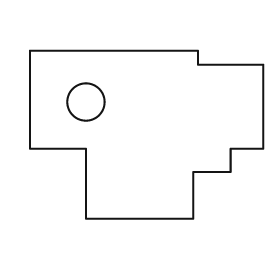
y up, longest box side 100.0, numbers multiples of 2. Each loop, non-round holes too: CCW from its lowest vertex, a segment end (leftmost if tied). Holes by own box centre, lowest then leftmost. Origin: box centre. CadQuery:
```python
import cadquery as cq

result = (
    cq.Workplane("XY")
    .moveTo(-26.0, -36.0)
    .lineTo(20.0, -36.0)
    .lineTo(20.0, -16.0)
    .lineTo(36.0, -16.0)
    .lineTo(36.0, -6.0)
    .lineTo(50.0, -6.0)
    .lineTo(50.0, 30.0)
    .lineTo(22.0, 30.0)
    .lineTo(22.0, 36.0)
    .lineTo(-50.0, 36.0)
    .lineTo(-50.0, -6.0)
    .lineTo(-26.0, -6.0)
    .close()
    .moveTo(-26.0, 14.0)
    .circle(8.0)
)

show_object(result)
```